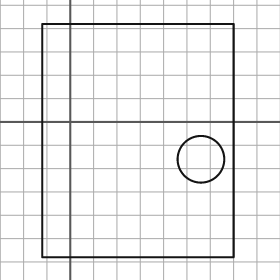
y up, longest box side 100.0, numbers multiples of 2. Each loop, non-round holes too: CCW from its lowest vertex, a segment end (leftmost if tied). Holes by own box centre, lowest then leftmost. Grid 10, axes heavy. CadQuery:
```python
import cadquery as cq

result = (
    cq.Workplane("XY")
    .moveTo(-12.0, -58.0)
    .lineTo(70.0, -58.0)
    .lineTo(70.0, 42.0)
    .lineTo(-12.0, 42.0)
    .close()
    .moveTo(56.0, -16.0)
    .circle(10.0)
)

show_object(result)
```